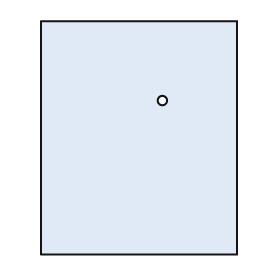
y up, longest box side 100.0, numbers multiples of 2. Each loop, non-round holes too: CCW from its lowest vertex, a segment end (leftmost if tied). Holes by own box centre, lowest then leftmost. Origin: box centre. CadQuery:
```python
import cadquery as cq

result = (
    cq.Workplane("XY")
    .moveTo(-42.0, -50.0)
    .lineTo(42.0, -50.0)
    .lineTo(42.0, 50.0)
    .lineTo(-42.0, 50.0)
    .close()
    .moveTo(10.0, 16.0)
    .circle(2.0)
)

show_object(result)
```